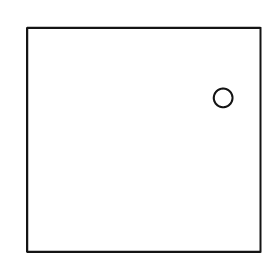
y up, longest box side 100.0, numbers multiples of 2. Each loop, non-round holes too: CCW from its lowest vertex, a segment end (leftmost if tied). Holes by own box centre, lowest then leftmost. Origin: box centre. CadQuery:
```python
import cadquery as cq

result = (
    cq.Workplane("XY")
    .moveTo(-50.0, -48.0)
    .lineTo(50.0, -48.0)
    .lineTo(50.0, 48.0)
    .lineTo(-50.0, 48.0)
    .close()
    .moveTo(34.0, 18.0)
    .circle(4.0)
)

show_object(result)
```